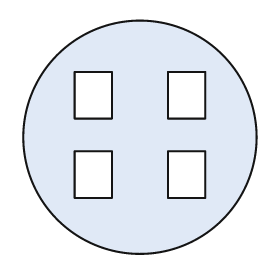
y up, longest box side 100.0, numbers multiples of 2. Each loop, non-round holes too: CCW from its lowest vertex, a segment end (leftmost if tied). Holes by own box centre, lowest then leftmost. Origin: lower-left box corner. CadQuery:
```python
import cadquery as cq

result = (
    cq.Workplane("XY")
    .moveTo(50.0, 50.0)
    .circle(50.0)
    .moveTo(22.0, 24.0)
    .lineTo(38.0, 24.0)
    .lineTo(38.0, 44.0)
    .lineTo(22.0, 44.0)
    .close()
    .moveTo(62.0, 24.0)
    .lineTo(78.0, 24.0)
    .lineTo(78.0, 44.0)
    .lineTo(62.0, 44.0)
    .close()
    .moveTo(22.0, 58.0)
    .lineTo(38.0, 58.0)
    .lineTo(38.0, 78.0)
    .lineTo(22.0, 78.0)
    .close()
    .moveTo(62.0, 58.0)
    .lineTo(78.0, 58.0)
    .lineTo(78.0, 78.0)
    .lineTo(62.0, 78.0)
    .close()
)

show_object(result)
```